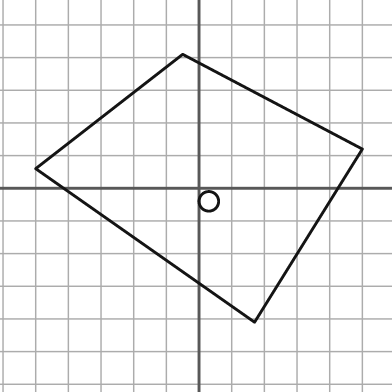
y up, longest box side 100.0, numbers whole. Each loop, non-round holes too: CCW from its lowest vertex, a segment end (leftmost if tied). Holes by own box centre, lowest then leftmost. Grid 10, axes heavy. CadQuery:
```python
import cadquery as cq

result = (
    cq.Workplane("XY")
    .moveTo(17.0, -41.0)
    .lineTo(50.0, 12.0)
    .lineTo(-5.0, 41.0)
    .lineTo(-50.0, 6.0)
    .close()
    .moveTo(3.0, -4.0)
    .circle(3.0)
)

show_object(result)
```